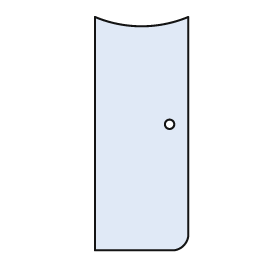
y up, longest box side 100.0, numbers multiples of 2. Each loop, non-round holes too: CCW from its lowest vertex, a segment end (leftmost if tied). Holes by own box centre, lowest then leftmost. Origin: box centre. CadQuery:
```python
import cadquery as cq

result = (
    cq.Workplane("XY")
    .moveTo(-20.0, -50.0)
    .lineTo(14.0, -50.0)
    .threePointArc((18.0, -48.0), (20.0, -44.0))
    .lineTo(20.0, 50.0)
    .threePointArc((0.0, 46.0), (-20.0, 50.0))
    .close()
    .moveTo(12.0, 4.0)
    .circle(2.0)
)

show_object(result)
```